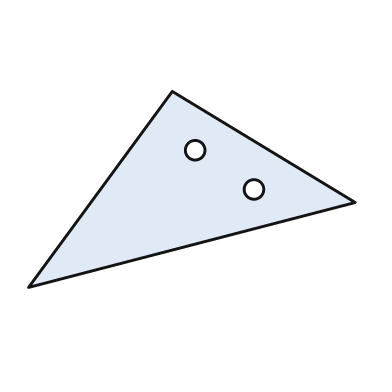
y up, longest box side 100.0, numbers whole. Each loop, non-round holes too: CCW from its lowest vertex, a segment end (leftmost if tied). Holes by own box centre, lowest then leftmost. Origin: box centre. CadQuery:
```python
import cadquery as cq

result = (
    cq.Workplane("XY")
    .moveTo(-50.0, -30.0)
    .lineTo(50.0, -4.0)
    .lineTo(-6.0, 30.0)
    .close()
    .moveTo(19.0, 0.0)
    .circle(3.0)
    .moveTo(1.0, 12.0)
    .circle(3.0)
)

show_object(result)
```